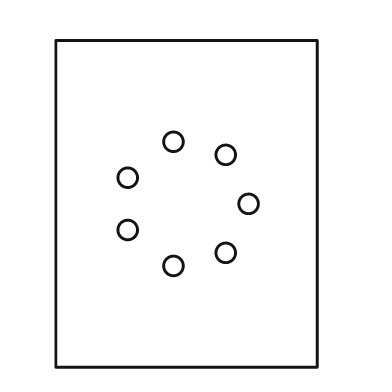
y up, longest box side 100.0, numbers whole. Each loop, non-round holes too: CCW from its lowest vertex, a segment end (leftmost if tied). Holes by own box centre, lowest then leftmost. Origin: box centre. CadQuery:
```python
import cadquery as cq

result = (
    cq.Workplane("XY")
    .moveTo(-40.0, -50.0)
    .lineTo(40.0, -50.0)
    .lineTo(40.0, 50.0)
    .lineTo(-40.0, 50.0)
    .close()
    .moveTo(-4.0, -19.0)
    .circle(3.0)
    .moveTo(12.0, -15.0)
    .circle(3.0)
    .moveTo(-18.0, -8.0)
    .circle(3.0)
    .moveTo(19.0, 0.0)
    .circle(3.0)
    .moveTo(-18.0, 8.0)
    .circle(3.0)
    .moveTo(12.0, 15.0)
    .circle(3.0)
    .moveTo(-4.0, 19.0)
    .circle(3.0)
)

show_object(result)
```